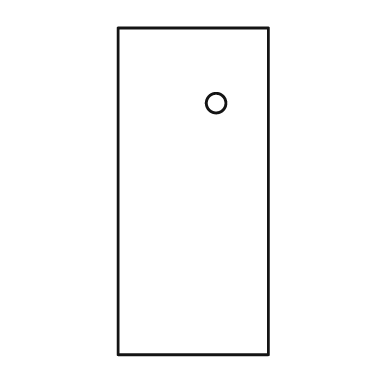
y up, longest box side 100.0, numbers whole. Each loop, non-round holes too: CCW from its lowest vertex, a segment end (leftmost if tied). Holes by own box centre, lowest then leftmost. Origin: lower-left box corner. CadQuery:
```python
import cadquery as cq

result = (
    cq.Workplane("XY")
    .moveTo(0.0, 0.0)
    .lineTo(46.0, 0.0)
    .lineTo(46.0, 100.0)
    .lineTo(0.0, 100.0)
    .close()
    .moveTo(30.0, 77.0)
    .circle(3.0)
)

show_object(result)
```